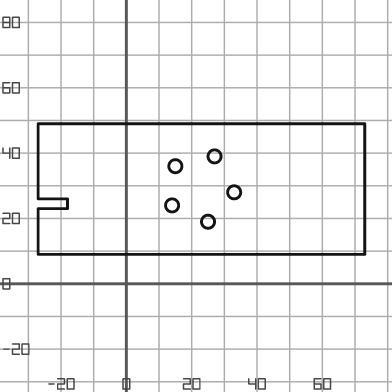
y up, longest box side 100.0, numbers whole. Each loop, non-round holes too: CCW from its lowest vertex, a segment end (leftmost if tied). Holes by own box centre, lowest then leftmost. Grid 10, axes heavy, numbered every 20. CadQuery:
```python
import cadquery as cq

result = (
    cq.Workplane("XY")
    .moveTo(-27.0, 9.0)
    .lineTo(73.0, 9.0)
    .lineTo(73.0, 49.0)
    .lineTo(-27.0, 49.0)
    .lineTo(-27.0, 26.0)
    .lineTo(-18.0, 26.0)
    .lineTo(-18.0, 23.0)
    .lineTo(-27.0, 23.0)
    .close()
    .moveTo(25.0, 19.0)
    .circle(2.0)
    .moveTo(14.0, 24.0)
    .circle(2.0)
    .moveTo(33.0, 28.0)
    .circle(2.0)
    .moveTo(15.0, 36.0)
    .circle(2.0)
    .moveTo(27.0, 39.0)
    .circle(2.0)
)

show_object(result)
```